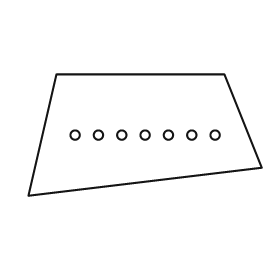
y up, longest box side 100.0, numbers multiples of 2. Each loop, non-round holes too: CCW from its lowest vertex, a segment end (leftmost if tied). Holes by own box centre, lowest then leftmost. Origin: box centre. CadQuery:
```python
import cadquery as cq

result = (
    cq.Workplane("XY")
    .moveTo(-50.0, -26.0)
    .lineTo(50.0, -14.0)
    .lineTo(34.0, 26.0)
    .lineTo(-38.0, 26.0)
    .close()
    .moveTo(-30.0, 0.0)
    .circle(2.0)
    .moveTo(-20.0, 0.0)
    .circle(2.0)
    .moveTo(-10.0, 0.0)
    .circle(2.0)
    .moveTo(0.0, 0.0)
    .circle(2.0)
    .moveTo(10.0, 0.0)
    .circle(2.0)
    .moveTo(20.0, 0.0)
    .circle(2.0)
    .moveTo(30.0, 0.0)
    .circle(2.0)
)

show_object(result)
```